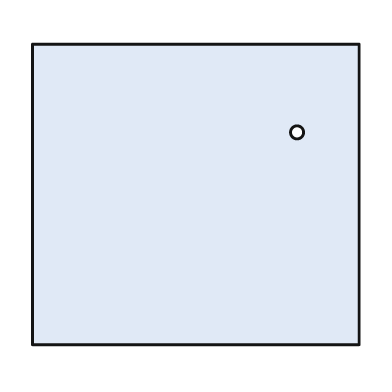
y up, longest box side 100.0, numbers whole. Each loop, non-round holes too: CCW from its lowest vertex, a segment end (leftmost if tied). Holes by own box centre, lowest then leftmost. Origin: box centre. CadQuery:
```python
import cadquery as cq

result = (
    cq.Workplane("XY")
    .moveTo(-50.0, -46.0)
    .lineTo(50.0, -46.0)
    .lineTo(50.0, 46.0)
    .lineTo(-50.0, 46.0)
    .close()
    .moveTo(31.0, 19.0)
    .circle(2.0)
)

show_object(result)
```